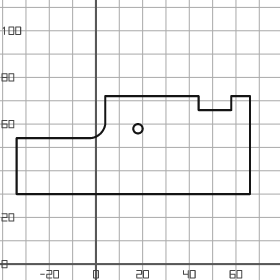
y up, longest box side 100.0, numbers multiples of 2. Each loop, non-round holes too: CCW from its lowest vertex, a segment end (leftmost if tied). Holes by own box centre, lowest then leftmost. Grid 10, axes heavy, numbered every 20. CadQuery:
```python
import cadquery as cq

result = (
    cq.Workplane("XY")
    .moveTo(-34.0, 30.0)
    .lineTo(66.0, 30.0)
    .lineTo(66.0, 72.0)
    .lineTo(58.0, 72.0)
    .lineTo(58.0, 66.0)
    .lineTo(44.0, 66.0)
    .lineTo(44.0, 72.0)
    .lineTo(4.0, 72.0)
    .lineTo(4.0, 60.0)
    .threePointArc((2.0, 56.0), (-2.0, 54.0))
    .lineTo(-34.0, 54.0)
    .close()
    .moveTo(18.0, 58.0)
    .circle(2.0)
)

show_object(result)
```